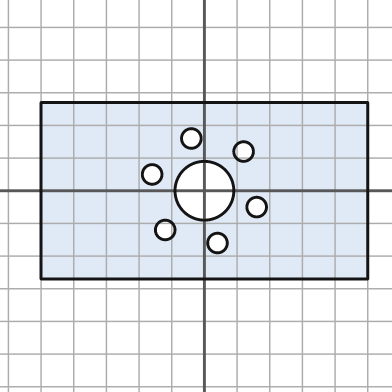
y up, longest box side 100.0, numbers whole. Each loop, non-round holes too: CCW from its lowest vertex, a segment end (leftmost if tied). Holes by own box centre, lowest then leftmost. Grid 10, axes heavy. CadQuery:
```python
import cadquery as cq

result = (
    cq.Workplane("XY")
    .moveTo(-50.0, -27.0)
    .lineTo(50.0, -27.0)
    .lineTo(50.0, 27.0)
    .lineTo(-50.0, 27.0)
    .close()
    .moveTo(4.0, -16.0)
    .circle(3.0)
    .moveTo(-12.0, -12.0)
    .circle(3.0)
    .moveTo(16.0, -5.0)
    .circle(3.0)
    .moveTo(0.0, 0.0)
    .circle(9.0)
    .moveTo(-16.0, 5.0)
    .circle(3.0)
    .moveTo(12.0, 12.0)
    .circle(3.0)
    .moveTo(-4.0, 16.0)
    .circle(3.0)
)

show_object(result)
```